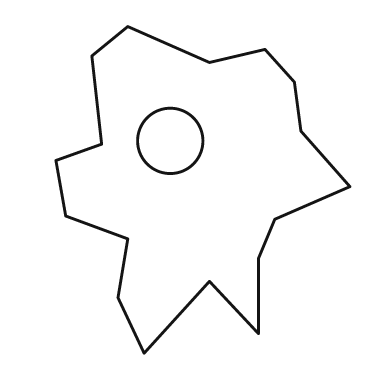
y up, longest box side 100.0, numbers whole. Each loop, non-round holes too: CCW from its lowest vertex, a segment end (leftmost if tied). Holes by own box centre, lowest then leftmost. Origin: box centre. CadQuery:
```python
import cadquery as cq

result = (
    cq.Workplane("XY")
    .moveTo(-18.0, -50.0)
    .lineTo(2.0, -28.0)
    .lineTo(17.0, -44.0)
    .lineTo(17.0, -21.0)
    .lineTo(22.0, -9.0)
    .lineTo(45.0, 1.0)
    .lineTo(30.0, 18.0)
    .lineTo(28.0, 33.0)
    .lineTo(19.0, 43.0)
    .lineTo(2.0, 39.0)
    .lineTo(-23.0, 50.0)
    .lineTo(-34.0, 41.0)
    .lineTo(-31.0, 14.0)
    .lineTo(-45.0, 9.0)
    .lineTo(-42.0, -8.0)
    .lineTo(-23.0, -15.0)
    .lineTo(-26.0, -33.0)
    .close()
    .moveTo(-10.0, 15.0)
    .circle(10.0)
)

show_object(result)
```